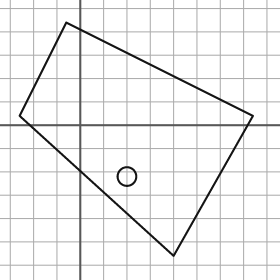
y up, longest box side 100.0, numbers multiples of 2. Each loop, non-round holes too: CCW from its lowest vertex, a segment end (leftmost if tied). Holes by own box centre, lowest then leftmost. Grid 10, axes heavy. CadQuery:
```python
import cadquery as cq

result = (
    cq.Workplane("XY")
    .moveTo(40.0, -56.0)
    .lineTo(74.0, 4.0)
    .lineTo(-6.0, 44.0)
    .lineTo(-26.0, 4.0)
    .close()
    .moveTo(20.0, -22.0)
    .circle(4.0)
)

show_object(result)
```